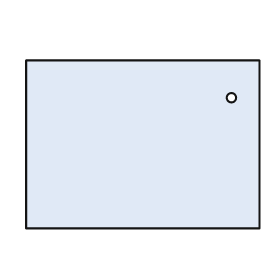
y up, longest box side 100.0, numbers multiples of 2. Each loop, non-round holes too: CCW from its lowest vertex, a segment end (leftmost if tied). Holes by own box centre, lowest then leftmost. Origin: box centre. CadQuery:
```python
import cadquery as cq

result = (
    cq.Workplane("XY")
    .moveTo(-50.0, -36.0)
    .lineTo(50.0, -36.0)
    .lineTo(50.0, 36.0)
    .lineTo(-50.0, 36.0)
    .close()
    .moveTo(38.0, 20.0)
    .circle(2.0)
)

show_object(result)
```